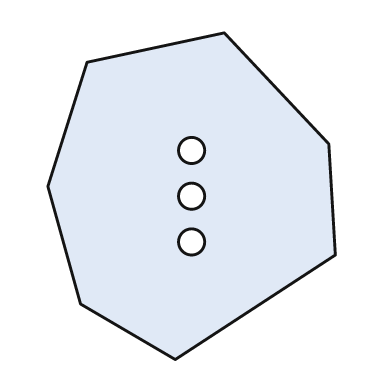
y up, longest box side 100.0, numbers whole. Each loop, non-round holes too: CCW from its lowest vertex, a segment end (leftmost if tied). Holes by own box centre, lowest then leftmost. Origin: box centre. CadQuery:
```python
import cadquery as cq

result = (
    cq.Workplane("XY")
    .moveTo(-5.0, -50.0)
    .lineTo(44.0, -18.0)
    .lineTo(42.0, 16.0)
    .lineTo(10.0, 50.0)
    .lineTo(-32.0, 41.0)
    .lineTo(-44.0, 3.0)
    .lineTo(-34.0, -33.0)
    .close()
    .moveTo(0.0, -14.0)
    .circle(4.0)
    .moveTo(0.0, 0.0)
    .circle(4.0)
    .moveTo(0.0, 14.0)
    .circle(4.0)
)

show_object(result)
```